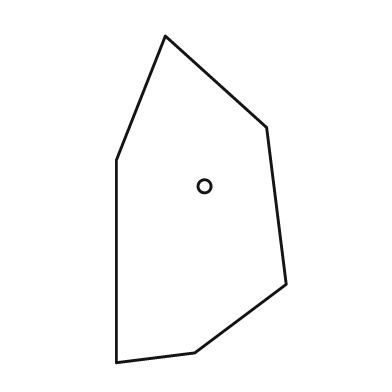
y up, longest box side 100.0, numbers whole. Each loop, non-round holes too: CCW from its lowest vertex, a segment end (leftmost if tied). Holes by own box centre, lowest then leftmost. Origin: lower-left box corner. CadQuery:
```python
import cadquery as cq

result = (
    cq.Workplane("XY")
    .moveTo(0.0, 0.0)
    .lineTo(24.0, 3.0)
    .lineTo(52.0, 24.0)
    .lineTo(46.0, 72.0)
    .lineTo(15.0, 100.0)
    .lineTo(0.0, 62.0)
    .close()
    .moveTo(27.0, 54.0)
    .circle(2.0)
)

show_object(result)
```